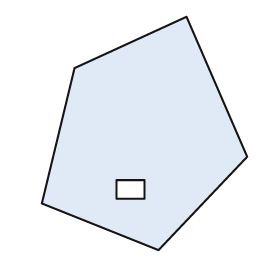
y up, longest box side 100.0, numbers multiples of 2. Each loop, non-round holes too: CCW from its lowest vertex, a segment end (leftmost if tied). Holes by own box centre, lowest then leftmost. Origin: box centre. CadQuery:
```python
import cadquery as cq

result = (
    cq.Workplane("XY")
    .moveTo(6.0, -50.0)
    .lineTo(44.0, -10.0)
    .lineTo(18.0, 50.0)
    .lineTo(-30.0, 28.0)
    .lineTo(-44.0, -30.0)
    .close()
    .moveTo(-12.0, -28.0)
    .lineTo(0.0, -28.0)
    .lineTo(0.0, -20.0)
    .lineTo(-12.0, -20.0)
    .close()
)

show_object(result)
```